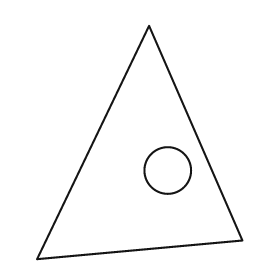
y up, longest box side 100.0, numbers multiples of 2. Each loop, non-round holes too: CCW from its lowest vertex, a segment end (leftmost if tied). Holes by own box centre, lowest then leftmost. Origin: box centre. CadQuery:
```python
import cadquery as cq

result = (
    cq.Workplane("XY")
    .moveTo(-44.0, -50.0)
    .lineTo(44.0, -42.0)
    .lineTo(4.0, 50.0)
    .close()
    .moveTo(12.0, -12.0)
    .circle(10.0)
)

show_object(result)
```